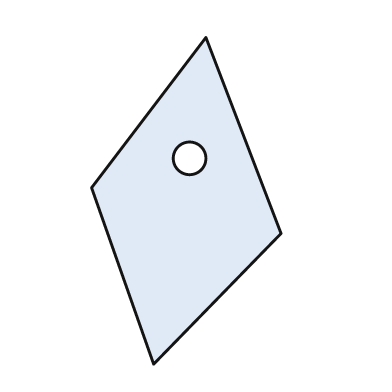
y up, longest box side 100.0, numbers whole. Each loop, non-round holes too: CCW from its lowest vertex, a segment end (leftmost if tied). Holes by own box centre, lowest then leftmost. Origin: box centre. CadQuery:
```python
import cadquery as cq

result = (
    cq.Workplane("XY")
    .moveTo(-10.0, -50.0)
    .lineTo(29.0, -10.0)
    .lineTo(6.0, 50.0)
    .lineTo(-29.0, 4.0)
    .close()
    .moveTo(1.0, 13.0)
    .circle(5.0)
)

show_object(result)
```